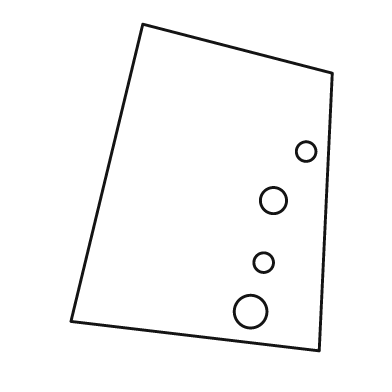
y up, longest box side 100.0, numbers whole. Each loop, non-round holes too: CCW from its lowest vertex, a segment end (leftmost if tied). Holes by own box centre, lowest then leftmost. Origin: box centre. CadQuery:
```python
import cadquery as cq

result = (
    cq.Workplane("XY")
    .moveTo(36.0, -50.0)
    .lineTo(40.0, 35.0)
    .lineTo(-18.0, 50.0)
    .lineTo(-40.0, -41.0)
    .close()
    .moveTo(15.0, -38.0)
    .circle(5.0)
    .moveTo(19.0, -23.0)
    .circle(3.0)
    .moveTo(22.0, -4.0)
    .circle(4.0)
    .moveTo(32.0, 11.0)
    .circle(3.0)
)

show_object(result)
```